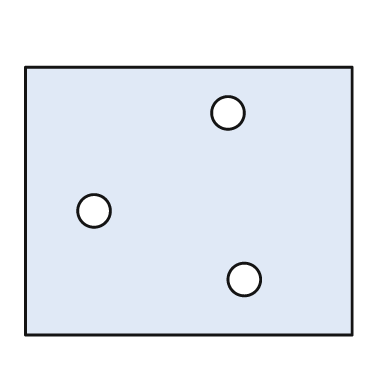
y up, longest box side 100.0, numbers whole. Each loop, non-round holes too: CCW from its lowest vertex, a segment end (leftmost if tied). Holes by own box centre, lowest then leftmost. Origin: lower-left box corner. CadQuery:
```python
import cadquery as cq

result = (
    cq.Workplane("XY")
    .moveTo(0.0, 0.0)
    .lineTo(100.0, 0.0)
    .lineTo(100.0, 82.0)
    .lineTo(0.0, 82.0)
    .close()
    .moveTo(67.0, 17.0)
    .circle(5.0)
    .moveTo(21.0, 38.0)
    .circle(5.0)
    .moveTo(62.0, 68.0)
    .circle(5.0)
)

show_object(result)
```